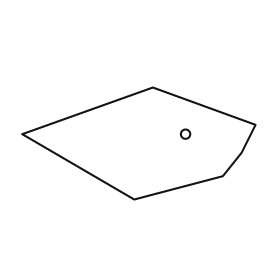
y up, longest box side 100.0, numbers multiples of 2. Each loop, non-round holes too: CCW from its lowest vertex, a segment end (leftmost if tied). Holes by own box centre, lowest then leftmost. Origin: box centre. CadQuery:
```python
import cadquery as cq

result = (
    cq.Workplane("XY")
    .moveTo(-2.0, -24.0)
    .lineTo(36.0, -14.0)
    .lineTo(44.0, -4.0)
    .lineTo(50.0, 8.0)
    .lineTo(6.0, 24.0)
    .lineTo(-50.0, 4.0)
    .close()
    .moveTo(20.0, 4.0)
    .circle(2.0)
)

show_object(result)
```